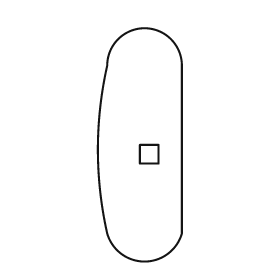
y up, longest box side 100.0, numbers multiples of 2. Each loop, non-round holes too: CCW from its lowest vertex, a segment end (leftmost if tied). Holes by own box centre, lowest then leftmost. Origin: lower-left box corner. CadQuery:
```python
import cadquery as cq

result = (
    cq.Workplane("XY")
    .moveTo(4.0, 12.0)
    .threePointArc((20.0, 0.0), (36.0, 12.0))
    .lineTo(36.0, 84.0)
    .threePointArc((20.0, 100.0), (4.0, 84.0))
    .threePointArc((0.0, 48.0), (4.0, 12.0))
    .close()
    .moveTo(18.0, 42.0)
    .lineTo(26.0, 42.0)
    .lineTo(26.0, 50.0)
    .lineTo(18.0, 50.0)
    .close()
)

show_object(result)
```